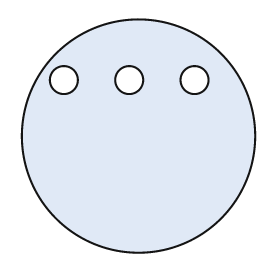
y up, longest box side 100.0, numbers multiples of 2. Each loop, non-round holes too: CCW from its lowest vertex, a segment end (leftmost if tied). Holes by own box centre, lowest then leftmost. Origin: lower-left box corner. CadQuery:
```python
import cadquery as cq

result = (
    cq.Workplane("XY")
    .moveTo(50.0, 50.0)
    .circle(50.0)
    .moveTo(18.0, 74.0)
    .circle(6.0)
    .moveTo(46.0, 74.0)
    .circle(6.0)
    .moveTo(74.0, 74.0)
    .circle(6.0)
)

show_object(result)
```